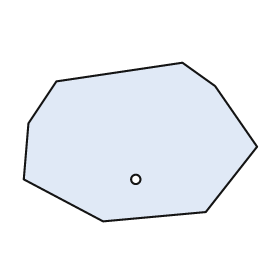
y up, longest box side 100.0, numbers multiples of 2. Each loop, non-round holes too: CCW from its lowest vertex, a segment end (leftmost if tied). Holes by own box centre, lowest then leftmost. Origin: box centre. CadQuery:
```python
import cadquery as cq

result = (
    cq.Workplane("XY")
    .moveTo(-16.0, -34.0)
    .lineTo(28.0, -30.0)
    .lineTo(50.0, -2.0)
    .lineTo(32.0, 24.0)
    .lineTo(18.0, 34.0)
    .lineTo(-36.0, 26.0)
    .lineTo(-48.0, 8.0)
    .lineTo(-50.0, -16.0)
    .close()
    .moveTo(-2.0, -16.0)
    .circle(2.0)
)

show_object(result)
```